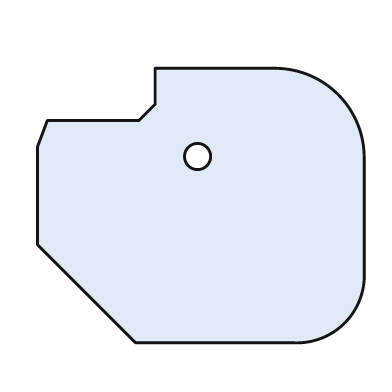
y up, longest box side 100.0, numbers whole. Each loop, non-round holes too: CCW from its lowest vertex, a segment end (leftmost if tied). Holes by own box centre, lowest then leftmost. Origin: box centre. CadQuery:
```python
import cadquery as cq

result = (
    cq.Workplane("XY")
    .moveTo(-20.0, -42.0)
    .lineTo(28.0, -42.0)
    .threePointArc((44.0, -36.0), (50.0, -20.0))
    .lineTo(50.0, 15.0)
    .threePointArc((42.0, 34.0), (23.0, 42.0))
    .lineTo(-14.0, 42.0)
    .lineTo(-14.0, 31.0)
    .lineTo(-19.0, 26.0)
    .lineTo(-47.0, 26.0)
    .lineTo(-50.0, 18.0)
    .lineTo(-50.0, -12.0)
    .close()
    .moveTo(-1.0, 15.0)
    .circle(4.0)
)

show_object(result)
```